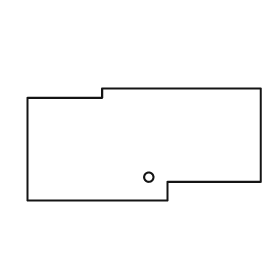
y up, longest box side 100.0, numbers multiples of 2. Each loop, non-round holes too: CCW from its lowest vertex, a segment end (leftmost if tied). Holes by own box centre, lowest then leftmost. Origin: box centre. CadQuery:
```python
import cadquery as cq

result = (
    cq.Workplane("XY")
    .moveTo(-50.0, -24.0)
    .lineTo(10.0, -24.0)
    .lineTo(10.0, -16.0)
    .lineTo(50.0, -16.0)
    .lineTo(50.0, 24.0)
    .lineTo(-18.0, 24.0)
    .lineTo(-18.0, 20.0)
    .lineTo(-50.0, 20.0)
    .close()
    .moveTo(2.0, -14.0)
    .circle(2.0)
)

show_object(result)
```